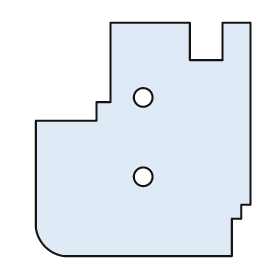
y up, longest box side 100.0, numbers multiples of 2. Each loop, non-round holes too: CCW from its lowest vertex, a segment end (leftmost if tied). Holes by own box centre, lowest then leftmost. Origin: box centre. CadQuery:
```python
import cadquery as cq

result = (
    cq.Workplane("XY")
    .moveTo(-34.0, -50.0)
    .lineTo(38.0, -50.0)
    .lineTo(38.0, -34.0)
    .lineTo(42.0, -34.0)
    .lineTo(42.0, -28.0)
    .lineTo(46.0, -28.0)
    .lineTo(46.0, 50.0)
    .lineTo(34.0, 50.0)
    .lineTo(34.0, 34.0)
    .lineTo(20.0, 34.0)
    .lineTo(20.0, 50.0)
    .lineTo(-14.0, 50.0)
    .lineTo(-14.0, 16.0)
    .lineTo(-20.0, 16.0)
    .lineTo(-20.0, 8.0)
    .lineTo(-46.0, 8.0)
    .lineTo(-46.0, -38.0)
    .threePointArc((-42.0, -46.0), (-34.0, -50.0))
    .close()
    .moveTo(0.0, -16.0)
    .circle(4.0)
    .moveTo(0.0, 18.0)
    .circle(4.0)
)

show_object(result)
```